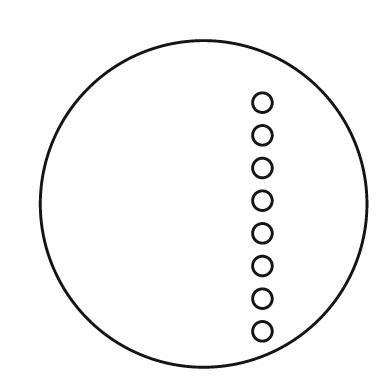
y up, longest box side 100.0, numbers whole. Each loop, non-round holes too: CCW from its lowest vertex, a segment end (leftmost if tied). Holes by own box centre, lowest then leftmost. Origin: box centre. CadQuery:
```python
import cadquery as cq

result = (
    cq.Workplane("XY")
    .moveTo(0.0, 0.0)
    .circle(50.0)
    .moveTo(18.0, -39.0)
    .circle(3.0)
    .moveTo(18.0, -29.0)
    .circle(3.0)
    .moveTo(18.0, -19.0)
    .circle(3.0)
    .moveTo(18.0, -9.0)
    .circle(3.0)
    .moveTo(18.0, 1.0)
    .circle(3.0)
    .moveTo(18.0, 11.0)
    .circle(3.0)
    .moveTo(18.0, 21.0)
    .circle(3.0)
    .moveTo(18.0, 31.0)
    .circle(3.0)
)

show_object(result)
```